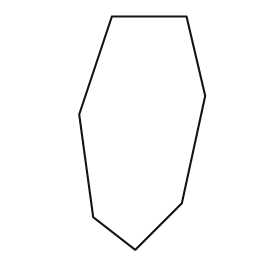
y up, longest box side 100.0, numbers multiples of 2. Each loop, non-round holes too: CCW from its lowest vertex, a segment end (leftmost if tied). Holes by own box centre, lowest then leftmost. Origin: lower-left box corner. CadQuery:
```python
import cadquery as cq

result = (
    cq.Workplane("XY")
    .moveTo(24.0, 0.0)
    .lineTo(44.0, 20.0)
    .lineTo(54.0, 66.0)
    .lineTo(46.0, 100.0)
    .lineTo(14.0, 100.0)
    .lineTo(0.0, 58.0)
    .lineTo(6.0, 14.0)
    .close()
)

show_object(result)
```